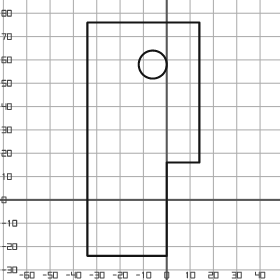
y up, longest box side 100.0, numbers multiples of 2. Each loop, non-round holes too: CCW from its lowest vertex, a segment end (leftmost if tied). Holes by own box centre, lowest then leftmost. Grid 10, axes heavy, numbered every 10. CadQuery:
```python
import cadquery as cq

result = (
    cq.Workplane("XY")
    .moveTo(-34.0, -24.0)
    .lineTo(0.0, -24.0)
    .lineTo(0.0, 16.0)
    .lineTo(14.0, 16.0)
    .lineTo(14.0, 76.0)
    .lineTo(-34.0, 76.0)
    .close()
    .moveTo(-6.0, 58.0)
    .circle(6.0)
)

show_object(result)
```